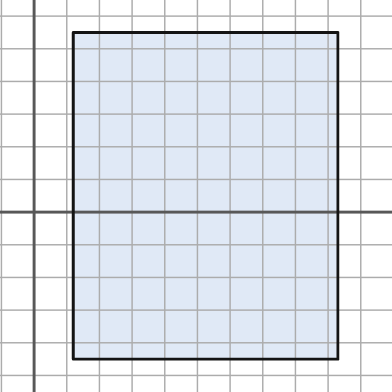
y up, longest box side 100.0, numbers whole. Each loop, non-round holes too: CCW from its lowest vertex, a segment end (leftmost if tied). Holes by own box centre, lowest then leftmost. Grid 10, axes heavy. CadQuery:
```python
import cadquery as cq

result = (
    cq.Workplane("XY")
    .moveTo(12.0, -45.0)
    .lineTo(93.0, -45.0)
    .lineTo(93.0, 55.0)
    .lineTo(12.0, 55.0)
    .close()
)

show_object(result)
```